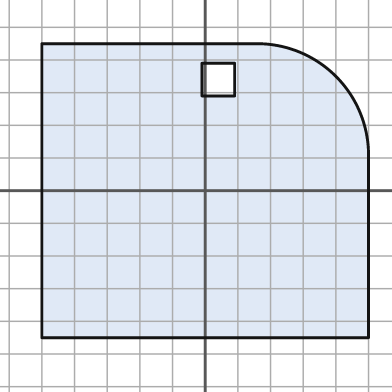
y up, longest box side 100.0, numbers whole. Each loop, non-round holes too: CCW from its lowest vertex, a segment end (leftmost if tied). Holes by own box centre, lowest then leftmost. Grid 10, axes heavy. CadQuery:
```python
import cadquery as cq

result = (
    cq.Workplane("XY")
    .moveTo(-50.0, -45.0)
    .lineTo(50.0, -45.0)
    .lineTo(50.0, 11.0)
    .threePointArc((40.0, 35.0), (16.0, 45.0))
    .lineTo(-50.0, 45.0)
    .close()
    .moveTo(-1.0, 29.0)
    .lineTo(9.0, 29.0)
    .lineTo(9.0, 39.0)
    .lineTo(-1.0, 39.0)
    .close()
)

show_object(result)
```